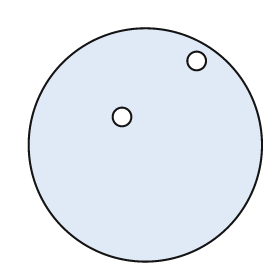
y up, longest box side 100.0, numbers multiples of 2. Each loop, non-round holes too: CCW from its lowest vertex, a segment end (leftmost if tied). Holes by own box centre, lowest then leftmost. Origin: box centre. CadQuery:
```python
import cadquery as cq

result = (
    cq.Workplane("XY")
    .moveTo(0.0, 0.0)
    .circle(50.0)
    .moveTo(-10.0, 12.0)
    .circle(4.0)
    .moveTo(22.0, 36.0)
    .circle(4.0)
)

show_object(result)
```